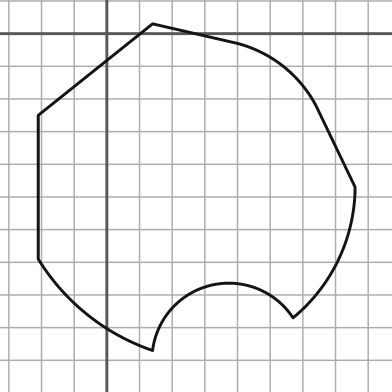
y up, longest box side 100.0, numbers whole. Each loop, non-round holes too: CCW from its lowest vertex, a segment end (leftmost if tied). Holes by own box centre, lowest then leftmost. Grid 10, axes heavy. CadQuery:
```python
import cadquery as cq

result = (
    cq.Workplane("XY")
    .moveTo(14.0, -97.0)
    .threePointArc((32.0, -77.0), (57.0, -87.0))
    .threePointArc((71.0, -69.0), (76.0, -47.0))
    .lineTo(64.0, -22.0)
    .threePointArc((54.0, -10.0), (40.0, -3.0))
    .lineTo(14.0, 3.0)
    .lineTo(-21.0, -25.0)
    .lineTo(-21.0, -69.0)
    .threePointArc((-6.0, -86.0), (14.0, -97.0))
    .close()
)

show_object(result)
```